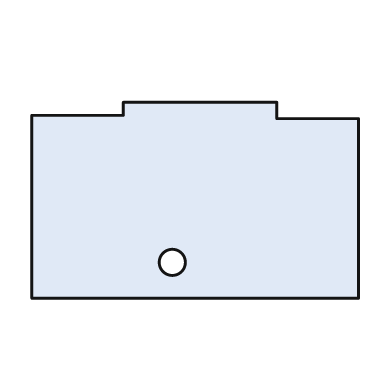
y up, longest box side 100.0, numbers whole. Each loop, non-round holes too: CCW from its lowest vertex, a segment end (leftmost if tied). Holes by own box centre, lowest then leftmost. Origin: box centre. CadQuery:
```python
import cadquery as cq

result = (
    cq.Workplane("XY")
    .moveTo(-50.0, -30.0)
    .lineTo(50.0, -30.0)
    .lineTo(50.0, 25.0)
    .lineTo(25.0, 25.0)
    .lineTo(25.0, 30.0)
    .lineTo(-22.0, 30.0)
    .lineTo(-22.0, 26.0)
    .lineTo(-50.0, 26.0)
    .close()
    .moveTo(-7.0, -19.0)
    .circle(4.0)
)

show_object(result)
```